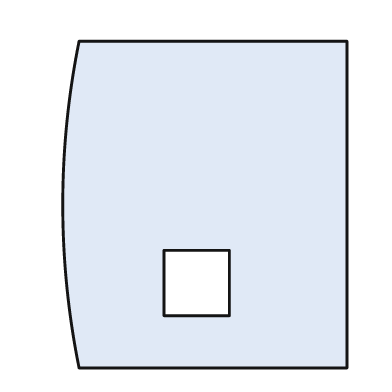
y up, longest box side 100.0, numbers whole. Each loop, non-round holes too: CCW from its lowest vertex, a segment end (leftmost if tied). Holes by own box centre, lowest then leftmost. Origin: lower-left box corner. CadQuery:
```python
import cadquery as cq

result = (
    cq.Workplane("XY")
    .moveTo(5.0, 0.0)
    .lineTo(87.0, 0.0)
    .lineTo(87.0, 100.0)
    .lineTo(5.0, 100.0)
    .threePointArc((0.0, 50.0), (5.0, 0.0))
    .close()
    .moveTo(31.0, 16.0)
    .lineTo(51.0, 16.0)
    .lineTo(51.0, 36.0)
    .lineTo(31.0, 36.0)
    .close()
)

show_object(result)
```